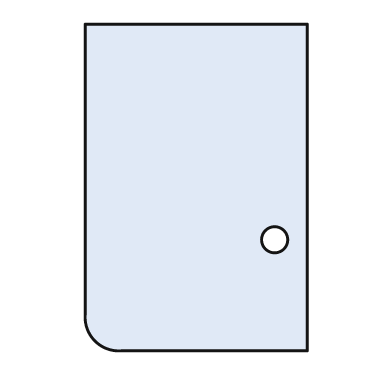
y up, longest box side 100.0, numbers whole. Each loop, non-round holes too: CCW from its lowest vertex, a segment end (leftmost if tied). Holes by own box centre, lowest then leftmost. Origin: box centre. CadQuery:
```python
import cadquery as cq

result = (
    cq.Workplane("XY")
    .moveTo(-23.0, -50.0)
    .lineTo(34.0, -50.0)
    .lineTo(34.0, 50.0)
    .lineTo(-34.0, 50.0)
    .lineTo(-34.0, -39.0)
    .threePointArc((-31.0, -47.0), (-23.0, -50.0))
    .close()
    .moveTo(24.0, -16.0)
    .circle(4.0)
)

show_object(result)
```